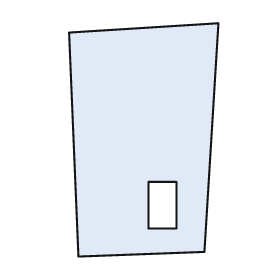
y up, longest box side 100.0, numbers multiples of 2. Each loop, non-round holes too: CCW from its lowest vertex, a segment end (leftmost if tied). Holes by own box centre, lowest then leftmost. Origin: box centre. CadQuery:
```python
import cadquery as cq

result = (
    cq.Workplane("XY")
    .moveTo(-28.0, -50.0)
    .lineTo(26.0, -48.0)
    .lineTo(32.0, 50.0)
    .lineTo(-32.0, 46.0)
    .close()
    .moveTo(2.0, -38.0)
    .lineTo(14.0, -38.0)
    .lineTo(14.0, -18.0)
    .lineTo(2.0, -18.0)
    .close()
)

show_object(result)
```